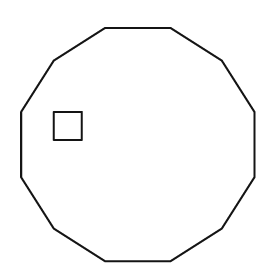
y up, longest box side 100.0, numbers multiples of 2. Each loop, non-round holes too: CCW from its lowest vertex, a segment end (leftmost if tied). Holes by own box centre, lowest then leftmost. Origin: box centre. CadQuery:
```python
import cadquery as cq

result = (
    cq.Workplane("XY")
    .moveTo(-14.0, -50.0)
    .lineTo(14.0, -50.0)
    .lineTo(36.0, -36.0)
    .lineTo(50.0, -14.0)
    .lineTo(50.0, 14.0)
    .lineTo(36.0, 36.0)
    .lineTo(14.0, 50.0)
    .lineTo(-14.0, 50.0)
    .lineTo(-36.0, 36.0)
    .lineTo(-50.0, 14.0)
    .lineTo(-50.0, -14.0)
    .lineTo(-36.0, -36.0)
    .close()
    .moveTo(-36.0, 2.0)
    .lineTo(-24.0, 2.0)
    .lineTo(-24.0, 14.0)
    .lineTo(-36.0, 14.0)
    .close()
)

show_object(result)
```